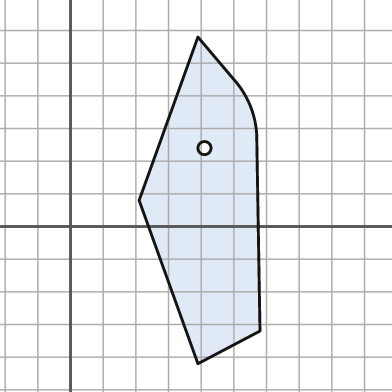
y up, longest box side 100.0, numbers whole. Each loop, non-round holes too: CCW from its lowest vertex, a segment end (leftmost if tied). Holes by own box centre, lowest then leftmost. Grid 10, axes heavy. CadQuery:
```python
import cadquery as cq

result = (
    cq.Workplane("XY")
    .moveTo(39.0, -42.0)
    .lineTo(58.0, -32.0)
    .lineTo(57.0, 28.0)
    .threePointArc((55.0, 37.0), (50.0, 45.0))
    .lineTo(39.0, 58.0)
    .lineTo(21.0, 8.0)
    .close()
    .moveTo(41.0, 24.0)
    .circle(2.0)
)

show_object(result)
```